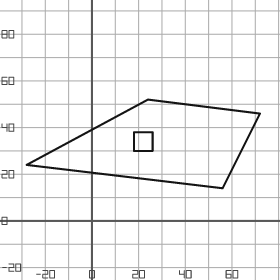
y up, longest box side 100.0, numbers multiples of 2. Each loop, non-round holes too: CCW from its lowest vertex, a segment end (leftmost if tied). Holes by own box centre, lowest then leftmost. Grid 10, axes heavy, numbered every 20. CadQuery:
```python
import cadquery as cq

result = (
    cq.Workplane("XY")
    .moveTo(56.0, 14.0)
    .lineTo(72.0, 46.0)
    .lineTo(24.0, 52.0)
    .lineTo(-28.0, 24.0)
    .close()
    .moveTo(18.0, 30.0)
    .lineTo(26.0, 30.0)
    .lineTo(26.0, 38.0)
    .lineTo(18.0, 38.0)
    .close()
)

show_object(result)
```